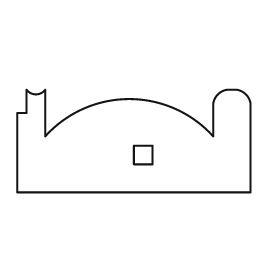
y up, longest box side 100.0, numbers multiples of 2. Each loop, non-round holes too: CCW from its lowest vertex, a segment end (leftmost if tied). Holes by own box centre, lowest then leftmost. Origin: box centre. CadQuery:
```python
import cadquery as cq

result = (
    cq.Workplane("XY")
    .moveTo(-50.0, -22.0)
    .lineTo(50.0, -22.0)
    .lineTo(50.0, 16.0)
    .threePointArc((48.0, 20.0), (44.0, 22.0))
    .lineTo(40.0, 22.0)
    .threePointArc((36.0, 20.0), (34.0, 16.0))
    .lineTo(34.0, 2.0)
    .threePointArc((-2.0, 18.0), (-38.0, 2.0))
    .lineTo(-38.0, 22.0)
    .threePointArc((-42.0, 20.0), (-46.0, 22.0))
    .lineTo(-46.0, 12.0)
    .lineTo(-50.0, 12.0)
    .close()
    .moveTo(0.0, -10.0)
    .lineTo(8.0, -10.0)
    .lineTo(8.0, -2.0)
    .lineTo(0.0, -2.0)
    .close()
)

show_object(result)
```